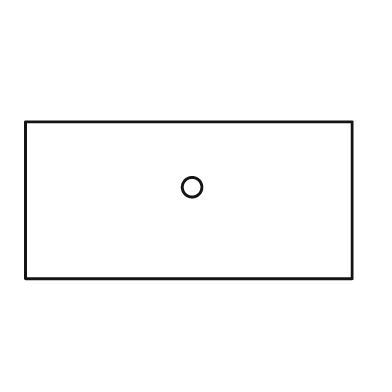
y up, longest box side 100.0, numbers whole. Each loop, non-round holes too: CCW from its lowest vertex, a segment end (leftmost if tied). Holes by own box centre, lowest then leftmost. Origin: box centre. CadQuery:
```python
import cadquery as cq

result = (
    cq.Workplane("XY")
    .moveTo(-50.0, -24.0)
    .lineTo(50.0, -24.0)
    .lineTo(50.0, 24.0)
    .lineTo(-50.0, 24.0)
    .close()
    .moveTo(1.0, 4.0)
    .circle(3.0)
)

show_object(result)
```